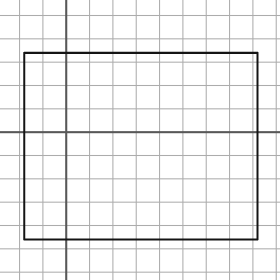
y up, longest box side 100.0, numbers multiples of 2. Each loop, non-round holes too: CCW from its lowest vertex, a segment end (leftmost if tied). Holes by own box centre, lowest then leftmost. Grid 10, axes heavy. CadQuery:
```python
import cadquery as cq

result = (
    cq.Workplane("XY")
    .moveTo(-18.0, -46.0)
    .lineTo(82.0, -46.0)
    .lineTo(82.0, 34.0)
    .lineTo(-18.0, 34.0)
    .close()
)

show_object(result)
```